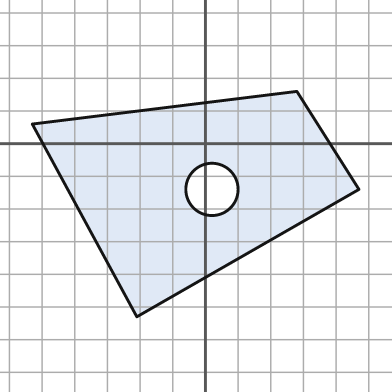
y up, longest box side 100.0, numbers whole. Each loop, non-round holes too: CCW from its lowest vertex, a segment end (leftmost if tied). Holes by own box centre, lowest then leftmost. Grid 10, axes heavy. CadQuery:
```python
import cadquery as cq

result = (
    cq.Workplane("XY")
    .moveTo(-21.0, -53.0)
    .lineTo(47.0, -14.0)
    .lineTo(28.0, 16.0)
    .lineTo(-53.0, 6.0)
    .close()
    .moveTo(2.0, -14.0)
    .circle(8.0)
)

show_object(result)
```